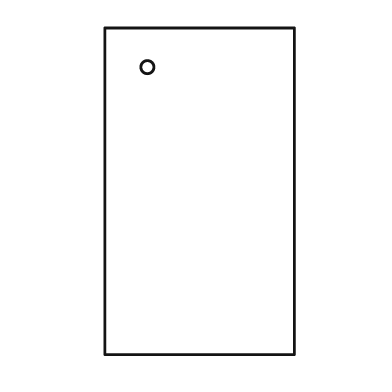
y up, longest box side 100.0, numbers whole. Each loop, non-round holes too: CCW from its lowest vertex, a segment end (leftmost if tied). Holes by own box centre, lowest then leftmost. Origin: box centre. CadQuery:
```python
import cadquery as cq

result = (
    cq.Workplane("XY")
    .moveTo(-29.0, -50.0)
    .lineTo(29.0, -50.0)
    .lineTo(29.0, 50.0)
    .lineTo(-29.0, 50.0)
    .close()
    .moveTo(-16.0, 38.0)
    .circle(2.0)
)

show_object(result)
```